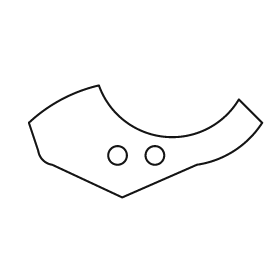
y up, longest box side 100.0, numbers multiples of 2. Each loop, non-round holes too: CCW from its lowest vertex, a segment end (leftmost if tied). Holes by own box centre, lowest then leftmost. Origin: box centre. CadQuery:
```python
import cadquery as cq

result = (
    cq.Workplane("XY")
    .moveTo(-10.0, -24.0)
    .lineTo(22.0, -10.0)
    .threePointArc((38.0, -4.0), (50.0, 8.0))
    .lineTo(40.0, 18.0)
    .threePointArc((8.0, 2.0), (-20.0, 24.0))
    .threePointArc((-36.0, 18.0), (-50.0, 8.0))
    .lineTo(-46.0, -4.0)
    .threePointArc((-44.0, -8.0), (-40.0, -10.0))
    .close()
    .moveTo(-12.0, -6.0)
    .circle(4.0)
    .moveTo(4.0, -6.0)
    .circle(4.0)
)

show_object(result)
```